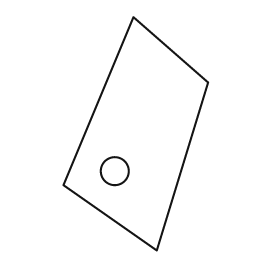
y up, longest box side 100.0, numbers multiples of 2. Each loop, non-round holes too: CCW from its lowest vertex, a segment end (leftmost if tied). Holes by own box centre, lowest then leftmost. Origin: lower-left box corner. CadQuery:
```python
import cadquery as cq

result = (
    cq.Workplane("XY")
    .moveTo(40.0, 0.0)
    .lineTo(62.0, 72.0)
    .lineTo(30.0, 100.0)
    .lineTo(0.0, 28.0)
    .close()
    .moveTo(22.0, 34.0)
    .circle(6.0)
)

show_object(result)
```